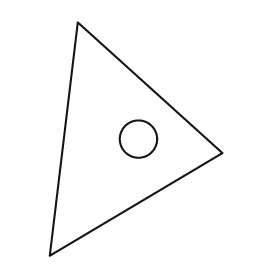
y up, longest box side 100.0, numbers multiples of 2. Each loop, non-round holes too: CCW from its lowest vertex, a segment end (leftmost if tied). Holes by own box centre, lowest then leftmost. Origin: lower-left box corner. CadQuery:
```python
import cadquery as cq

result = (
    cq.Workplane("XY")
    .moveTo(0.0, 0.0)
    .lineTo(74.0, 44.0)
    .lineTo(12.0, 100.0)
    .close()
    .moveTo(38.0, 50.0)
    .circle(8.0)
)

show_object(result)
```